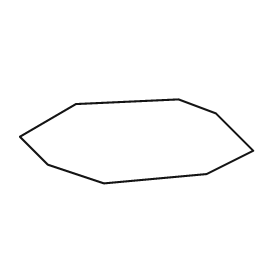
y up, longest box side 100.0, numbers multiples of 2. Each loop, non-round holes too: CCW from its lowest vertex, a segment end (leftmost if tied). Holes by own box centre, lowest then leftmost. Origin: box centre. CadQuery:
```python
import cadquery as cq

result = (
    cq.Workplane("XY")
    .moveTo(-14.0, -18.0)
    .lineTo(30.0, -14.0)
    .lineTo(50.0, -4.0)
    .lineTo(34.0, 12.0)
    .lineTo(18.0, 18.0)
    .lineTo(-26.0, 16.0)
    .lineTo(-50.0, 2.0)
    .lineTo(-38.0, -10.0)
    .close()
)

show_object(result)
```